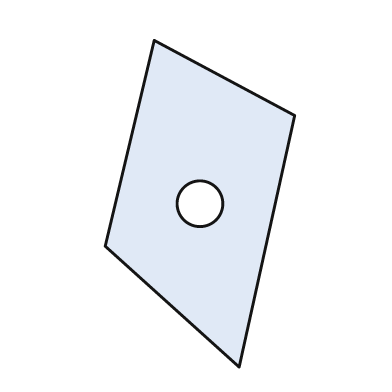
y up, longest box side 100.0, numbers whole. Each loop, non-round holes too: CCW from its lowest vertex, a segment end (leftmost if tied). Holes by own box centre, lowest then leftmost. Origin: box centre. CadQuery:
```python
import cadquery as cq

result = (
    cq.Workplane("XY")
    .moveTo(12.0, -50.0)
    .lineTo(29.0, 27.0)
    .lineTo(-14.0, 50.0)
    .lineTo(-29.0, -13.0)
    .close()
    .moveTo(0.0, 0.0)
    .circle(7.0)
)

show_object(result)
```